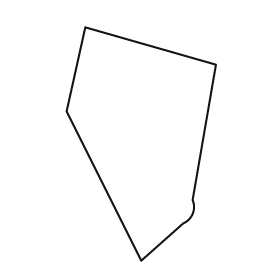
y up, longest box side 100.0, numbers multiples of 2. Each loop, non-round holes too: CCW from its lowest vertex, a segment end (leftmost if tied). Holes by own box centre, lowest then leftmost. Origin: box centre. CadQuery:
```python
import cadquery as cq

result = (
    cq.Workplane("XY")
    .moveTo(0.0, -50.0)
    .lineTo(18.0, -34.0)
    .threePointArc((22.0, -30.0), (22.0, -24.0))
    .lineTo(32.0, 34.0)
    .lineTo(-24.0, 50.0)
    .lineTo(-32.0, 14.0)
    .close()
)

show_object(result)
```